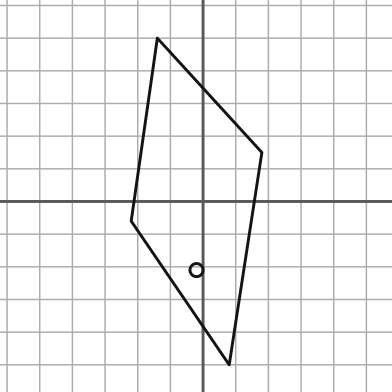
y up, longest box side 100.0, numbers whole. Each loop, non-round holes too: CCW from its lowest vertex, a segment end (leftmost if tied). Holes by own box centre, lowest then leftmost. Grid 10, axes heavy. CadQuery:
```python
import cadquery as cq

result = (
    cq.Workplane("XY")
    .moveTo(8.0, -50.0)
    .lineTo(18.0, 15.0)
    .lineTo(-14.0, 50.0)
    .lineTo(-22.0, -6.0)
    .close()
    .moveTo(-2.0, -21.0)
    .circle(2.0)
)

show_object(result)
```